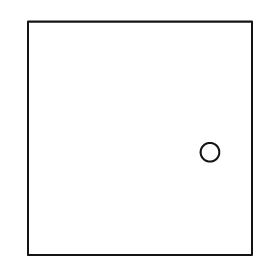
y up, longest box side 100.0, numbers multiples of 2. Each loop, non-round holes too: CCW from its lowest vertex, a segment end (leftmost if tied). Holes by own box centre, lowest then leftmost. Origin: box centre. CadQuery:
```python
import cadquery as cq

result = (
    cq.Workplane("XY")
    .moveTo(-48.0, -50.0)
    .lineTo(48.0, -50.0)
    .lineTo(48.0, 50.0)
    .lineTo(-48.0, 50.0)
    .close()
    .moveTo(30.0, -6.0)
    .circle(4.0)
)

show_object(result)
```